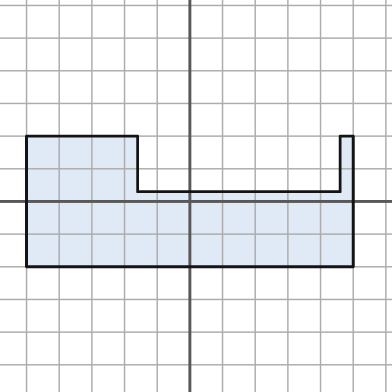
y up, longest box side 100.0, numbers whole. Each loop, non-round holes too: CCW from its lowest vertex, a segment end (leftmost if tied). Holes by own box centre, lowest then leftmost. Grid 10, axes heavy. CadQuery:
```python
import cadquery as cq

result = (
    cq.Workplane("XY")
    .moveTo(-50.0, -20.0)
    .lineTo(50.0, -20.0)
    .lineTo(50.0, 20.0)
    .lineTo(46.0, 20.0)
    .lineTo(46.0, 3.0)
    .lineTo(-16.0, 3.0)
    .lineTo(-16.0, 20.0)
    .lineTo(-50.0, 20.0)
    .close()
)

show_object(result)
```